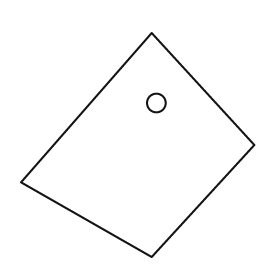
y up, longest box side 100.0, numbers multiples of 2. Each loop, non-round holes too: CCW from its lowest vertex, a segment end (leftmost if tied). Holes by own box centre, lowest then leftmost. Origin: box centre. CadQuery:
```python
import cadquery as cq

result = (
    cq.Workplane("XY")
    .moveTo(6.0, -48.0)
    .lineTo(50.0, 0.0)
    .lineTo(6.0, 48.0)
    .lineTo(-50.0, -16.0)
    .close()
    .moveTo(8.0, 18.0)
    .circle(4.0)
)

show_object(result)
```